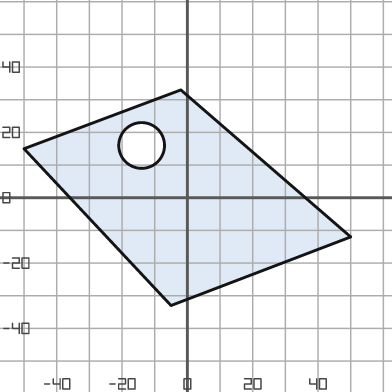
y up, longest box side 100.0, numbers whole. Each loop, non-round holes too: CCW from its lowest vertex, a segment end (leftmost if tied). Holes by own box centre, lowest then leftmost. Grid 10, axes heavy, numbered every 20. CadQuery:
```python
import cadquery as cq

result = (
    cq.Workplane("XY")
    .moveTo(-5.0, -33.0)
    .lineTo(50.0, -12.0)
    .lineTo(-2.0, 33.0)
    .lineTo(-50.0, 15.0)
    .close()
    .moveTo(-14.0, 16.0)
    .circle(7.0)
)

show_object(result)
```